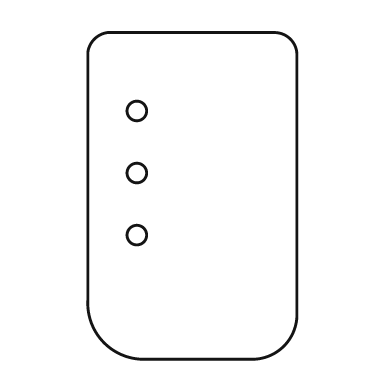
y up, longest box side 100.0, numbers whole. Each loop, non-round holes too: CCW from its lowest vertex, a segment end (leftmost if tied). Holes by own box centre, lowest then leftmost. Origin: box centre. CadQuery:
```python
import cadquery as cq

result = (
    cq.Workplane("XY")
    .moveTo(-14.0, -50.0)
    .lineTo(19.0, -50.0)
    .threePointArc((28.0, -46.0), (32.0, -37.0))
    .lineTo(32.0, 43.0)
    .threePointArc((30.0, 48.0), (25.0, 50.0))
    .lineTo(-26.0, 50.0)
    .threePointArc((-30.0, 48.0), (-32.0, 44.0))
    .lineTo(-32.0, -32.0)
    .threePointArc((-27.0, -45.0), (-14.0, -50.0))
    .close()
    .moveTo(-17.0, -12.0)
    .circle(3.0)
    .moveTo(-17.0, 7.0)
    .circle(3.0)
    .moveTo(-17.0, 26.0)
    .circle(3.0)
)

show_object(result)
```